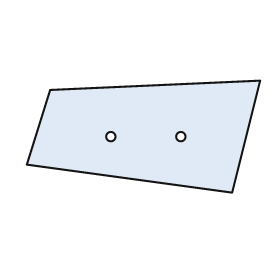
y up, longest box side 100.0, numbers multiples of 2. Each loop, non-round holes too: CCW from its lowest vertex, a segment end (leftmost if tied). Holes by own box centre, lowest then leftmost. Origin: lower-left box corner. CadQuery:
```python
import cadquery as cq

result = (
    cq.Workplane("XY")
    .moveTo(88.0, 0.0)
    .lineTo(100.0, 48.0)
    .lineTo(10.0, 44.0)
    .lineTo(0.0, 12.0)
    .close()
    .moveTo(36.0, 24.0)
    .circle(2.0)
    .moveTo(66.0, 24.0)
    .circle(2.0)
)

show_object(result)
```